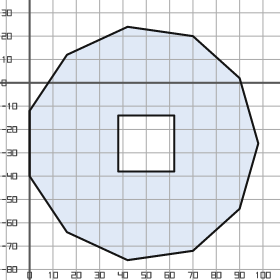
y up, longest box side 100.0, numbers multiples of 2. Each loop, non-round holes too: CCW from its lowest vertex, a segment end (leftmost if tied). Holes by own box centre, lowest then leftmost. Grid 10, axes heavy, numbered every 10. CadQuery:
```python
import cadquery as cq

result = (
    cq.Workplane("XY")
    .moveTo(42.0, -76.0)
    .lineTo(70.0, -72.0)
    .lineTo(90.0, -54.0)
    .lineTo(98.0, -26.0)
    .lineTo(90.0, 2.0)
    .lineTo(70.0, 20.0)
    .lineTo(42.0, 24.0)
    .lineTo(16.0, 12.0)
    .lineTo(0.0, -12.0)
    .lineTo(0.0, -40.0)
    .lineTo(16.0, -64.0)
    .close()
    .moveTo(38.0, -38.0)
    .lineTo(62.0, -38.0)
    .lineTo(62.0, -14.0)
    .lineTo(38.0, -14.0)
    .close()
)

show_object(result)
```